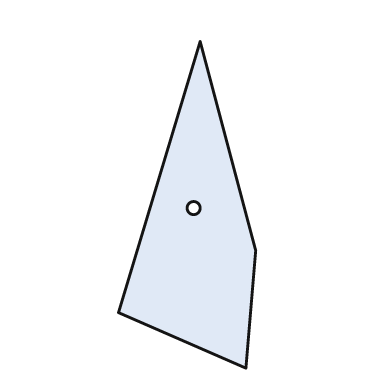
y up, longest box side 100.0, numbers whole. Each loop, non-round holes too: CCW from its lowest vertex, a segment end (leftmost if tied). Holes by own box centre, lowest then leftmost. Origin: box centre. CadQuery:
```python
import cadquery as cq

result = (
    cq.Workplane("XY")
    .moveTo(18.0, -50.0)
    .lineTo(21.0, -14.0)
    .lineTo(4.0, 50.0)
    .lineTo(-21.0, -33.0)
    .close()
    .moveTo(2.0, -1.0)
    .circle(2.0)
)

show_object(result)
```